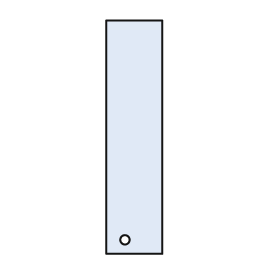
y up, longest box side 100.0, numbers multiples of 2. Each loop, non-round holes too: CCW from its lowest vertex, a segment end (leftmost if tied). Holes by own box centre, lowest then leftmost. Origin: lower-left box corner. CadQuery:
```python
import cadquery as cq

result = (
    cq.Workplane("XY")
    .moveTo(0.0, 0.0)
    .lineTo(24.0, 0.0)
    .lineTo(24.0, 100.0)
    .lineTo(0.0, 100.0)
    .close()
    .moveTo(8.0, 6.0)
    .circle(2.0)
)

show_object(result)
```